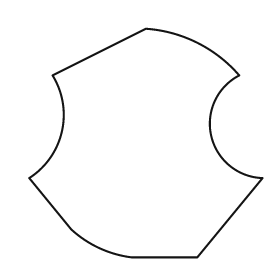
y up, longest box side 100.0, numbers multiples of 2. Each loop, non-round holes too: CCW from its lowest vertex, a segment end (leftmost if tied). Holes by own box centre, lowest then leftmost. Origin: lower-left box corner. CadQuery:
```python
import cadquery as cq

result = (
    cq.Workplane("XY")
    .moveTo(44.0, 0.0)
    .lineTo(72.0, 0.0)
    .lineTo(100.0, 34.0)
    .threePointArc((78.0, 52.0), (90.0, 78.0))
    .threePointArc((72.0, 92.0), (50.0, 98.0))
    .lineTo(10.0, 78.0)
    .threePointArc((14.0, 54.0), (0.0, 34.0))
    .lineTo(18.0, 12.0)
    .threePointArc((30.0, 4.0), (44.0, 0.0))
    .close()
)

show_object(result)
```